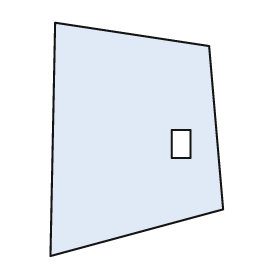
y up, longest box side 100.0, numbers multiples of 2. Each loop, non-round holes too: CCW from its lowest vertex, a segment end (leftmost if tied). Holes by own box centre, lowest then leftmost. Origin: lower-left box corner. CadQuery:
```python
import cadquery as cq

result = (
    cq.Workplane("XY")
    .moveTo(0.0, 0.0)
    .lineTo(74.0, 20.0)
    .lineTo(68.0, 90.0)
    .lineTo(2.0, 100.0)
    .close()
    .moveTo(52.0, 42.0)
    .lineTo(60.0, 42.0)
    .lineTo(60.0, 54.0)
    .lineTo(52.0, 54.0)
    .close()
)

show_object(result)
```